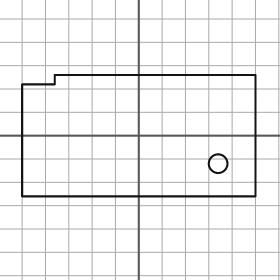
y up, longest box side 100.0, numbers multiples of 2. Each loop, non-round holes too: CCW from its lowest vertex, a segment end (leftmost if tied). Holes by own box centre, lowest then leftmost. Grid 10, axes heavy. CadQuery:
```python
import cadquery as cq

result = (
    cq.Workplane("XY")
    .moveTo(-50.0, -26.0)
    .lineTo(50.0, -26.0)
    .lineTo(50.0, 26.0)
    .lineTo(-36.0, 26.0)
    .lineTo(-36.0, 22.0)
    .lineTo(-50.0, 22.0)
    .close()
    .moveTo(34.0, -12.0)
    .circle(4.0)
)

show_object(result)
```